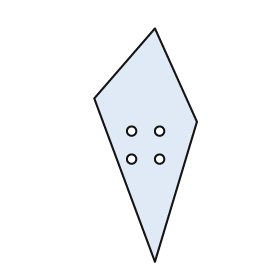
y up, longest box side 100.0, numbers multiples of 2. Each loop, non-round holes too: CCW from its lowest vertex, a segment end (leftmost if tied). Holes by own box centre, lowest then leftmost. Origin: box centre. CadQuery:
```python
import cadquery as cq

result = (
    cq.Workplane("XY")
    .moveTo(4.0, -50.0)
    .lineTo(22.0, 10.0)
    .lineTo(4.0, 50.0)
    .lineTo(-22.0, 20.0)
    .close()
    .moveTo(-6.0, -6.0)
    .circle(2.0)
    .moveTo(6.0, -6.0)
    .circle(2.0)
    .moveTo(-6.0, 6.0)
    .circle(2.0)
    .moveTo(6.0, 6.0)
    .circle(2.0)
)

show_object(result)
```